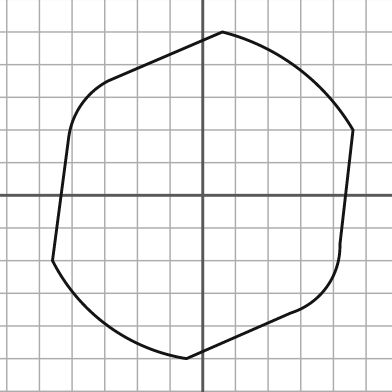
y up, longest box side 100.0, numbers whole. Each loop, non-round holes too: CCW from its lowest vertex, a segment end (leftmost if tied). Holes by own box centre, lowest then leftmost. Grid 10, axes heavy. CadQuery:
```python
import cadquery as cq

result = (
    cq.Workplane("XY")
    .moveTo(-5.0, -50.0)
    .lineTo(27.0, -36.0)
    .threePointArc((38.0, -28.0), (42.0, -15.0))
    .lineTo(46.0, 20.0)
    .threePointArc((29.0, 39.0), (6.0, 50.0))
    .lineTo(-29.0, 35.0)
    .threePointArc((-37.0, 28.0), (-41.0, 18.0))
    .lineTo(-46.0, -20.0)
    .threePointArc((-29.0, -40.0), (-5.0, -50.0))
    .close()
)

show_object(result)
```